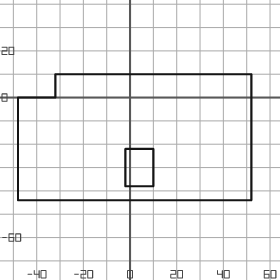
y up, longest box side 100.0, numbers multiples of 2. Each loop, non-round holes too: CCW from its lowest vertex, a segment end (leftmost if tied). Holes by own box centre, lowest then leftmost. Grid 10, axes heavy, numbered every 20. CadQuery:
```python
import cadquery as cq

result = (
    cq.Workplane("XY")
    .moveTo(-48.0, -44.0)
    .lineTo(52.0, -44.0)
    .lineTo(52.0, 10.0)
    .lineTo(-32.0, 10.0)
    .lineTo(-32.0, 0.0)
    .lineTo(-48.0, 0.0)
    .close()
    .moveTo(-2.0, -38.0)
    .lineTo(10.0, -38.0)
    .lineTo(10.0, -22.0)
    .lineTo(-2.0, -22.0)
    .close()
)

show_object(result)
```